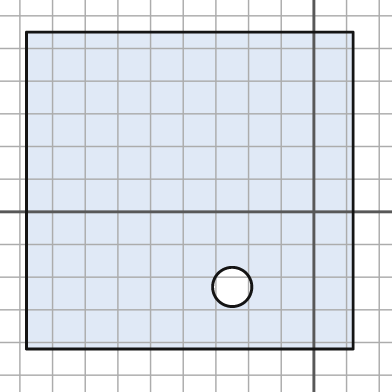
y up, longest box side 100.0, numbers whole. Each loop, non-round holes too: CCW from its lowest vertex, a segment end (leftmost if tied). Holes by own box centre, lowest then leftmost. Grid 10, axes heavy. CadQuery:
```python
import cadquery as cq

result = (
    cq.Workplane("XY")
    .moveTo(-88.0, -42.0)
    .lineTo(12.0, -42.0)
    .lineTo(12.0, 55.0)
    .lineTo(-88.0, 55.0)
    .close()
    .moveTo(-25.0, -23.0)
    .circle(6.0)
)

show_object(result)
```